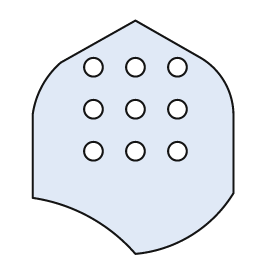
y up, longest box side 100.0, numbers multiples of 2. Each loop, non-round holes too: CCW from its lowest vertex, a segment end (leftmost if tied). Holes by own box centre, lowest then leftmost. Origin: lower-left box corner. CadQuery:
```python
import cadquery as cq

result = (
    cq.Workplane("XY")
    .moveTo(44.0, 0.0)
    .threePointArc((68.0, 8.0), (86.0, 26.0))
    .lineTo(86.0, 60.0)
    .threePointArc((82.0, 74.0), (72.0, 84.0))
    .lineTo(44.0, 100.0)
    .lineTo(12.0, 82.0)
    .threePointArc((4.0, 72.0), (0.0, 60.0))
    .lineTo(0.0, 24.0)
    .threePointArc((24.0, 16.0), (44.0, 0.0))
    .close()
    .moveTo(26.0, 44.0)
    .circle(4.0)
    .moveTo(44.0, 44.0)
    .circle(4.0)
    .moveTo(62.0, 44.0)
    .circle(4.0)
    .moveTo(26.0, 62.0)
    .circle(4.0)
    .moveTo(44.0, 62.0)
    .circle(4.0)
    .moveTo(62.0, 62.0)
    .circle(4.0)
    .moveTo(26.0, 80.0)
    .circle(4.0)
    .moveTo(44.0, 80.0)
    .circle(4.0)
    .moveTo(62.0, 80.0)
    .circle(4.0)
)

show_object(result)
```